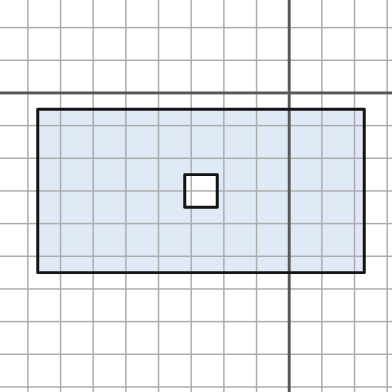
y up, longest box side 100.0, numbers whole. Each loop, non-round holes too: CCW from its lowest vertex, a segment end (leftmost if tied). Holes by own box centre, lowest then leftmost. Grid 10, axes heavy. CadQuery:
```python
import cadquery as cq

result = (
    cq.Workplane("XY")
    .moveTo(-77.0, -55.0)
    .lineTo(23.0, -55.0)
    .lineTo(23.0, -5.0)
    .lineTo(-77.0, -5.0)
    .close()
    .moveTo(-32.0, -35.0)
    .lineTo(-22.0, -35.0)
    .lineTo(-22.0, -25.0)
    .lineTo(-32.0, -25.0)
    .close()
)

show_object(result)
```